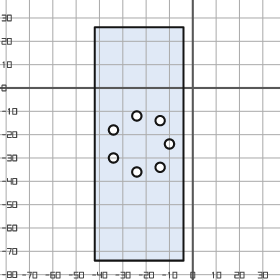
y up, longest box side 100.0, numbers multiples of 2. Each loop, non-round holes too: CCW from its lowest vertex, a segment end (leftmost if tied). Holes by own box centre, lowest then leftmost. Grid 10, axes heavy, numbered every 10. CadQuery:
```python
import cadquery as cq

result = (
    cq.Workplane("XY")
    .moveTo(-42.0, -74.0)
    .lineTo(-4.0, -74.0)
    .lineTo(-4.0, 26.0)
    .lineTo(-42.0, 26.0)
    .close()
    .moveTo(-24.0, -36.0)
    .circle(2.0)
    .moveTo(-14.0, -34.0)
    .circle(2.0)
    .moveTo(-34.0, -30.0)
    .circle(2.0)
    .moveTo(-10.0, -24.0)
    .circle(2.0)
    .moveTo(-34.0, -18.0)
    .circle(2.0)
    .moveTo(-14.0, -14.0)
    .circle(2.0)
    .moveTo(-24.0, -12.0)
    .circle(2.0)
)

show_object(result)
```